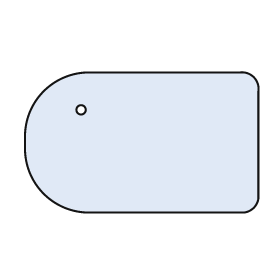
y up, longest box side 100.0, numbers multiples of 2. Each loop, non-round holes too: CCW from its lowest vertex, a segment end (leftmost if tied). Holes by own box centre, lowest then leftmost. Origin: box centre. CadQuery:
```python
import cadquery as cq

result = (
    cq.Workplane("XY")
    .moveTo(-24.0, -30.0)
    .lineTo(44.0, -30.0)
    .threePointArc((48.0, -28.0), (50.0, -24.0))
    .lineTo(50.0, 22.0)
    .threePointArc((48.0, 28.0), (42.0, 30.0))
    .lineTo(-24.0, 30.0)
    .threePointArc((-42.0, 22.0), (-50.0, 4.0))
    .lineTo(-50.0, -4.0)
    .threePointArc((-42.0, -22.0), (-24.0, -30.0))
    .close()
    .moveTo(-26.0, 14.0)
    .circle(2.0)
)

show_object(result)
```